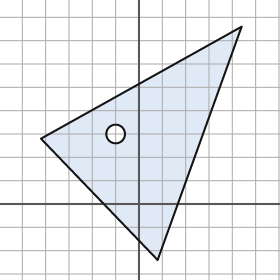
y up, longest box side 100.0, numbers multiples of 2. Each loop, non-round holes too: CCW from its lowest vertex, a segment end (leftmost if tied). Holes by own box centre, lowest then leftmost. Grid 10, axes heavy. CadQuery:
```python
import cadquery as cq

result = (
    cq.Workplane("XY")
    .moveTo(8.0, -24.0)
    .lineTo(44.0, 76.0)
    .lineTo(-42.0, 28.0)
    .close()
    .moveTo(-10.0, 30.0)
    .circle(4.0)
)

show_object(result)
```